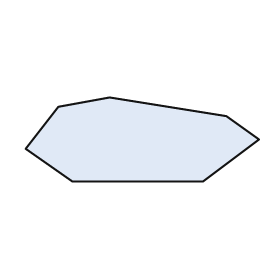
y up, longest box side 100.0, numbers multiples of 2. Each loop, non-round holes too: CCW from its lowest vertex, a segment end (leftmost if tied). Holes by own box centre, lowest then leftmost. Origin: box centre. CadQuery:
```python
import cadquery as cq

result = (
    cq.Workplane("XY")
    .moveTo(-30.0, -18.0)
    .lineTo(26.0, -18.0)
    .lineTo(50.0, 0.0)
    .lineTo(36.0, 10.0)
    .lineTo(-14.0, 18.0)
    .lineTo(-36.0, 14.0)
    .lineTo(-50.0, -4.0)
    .close()
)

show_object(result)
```